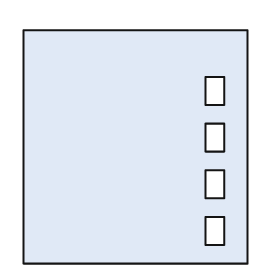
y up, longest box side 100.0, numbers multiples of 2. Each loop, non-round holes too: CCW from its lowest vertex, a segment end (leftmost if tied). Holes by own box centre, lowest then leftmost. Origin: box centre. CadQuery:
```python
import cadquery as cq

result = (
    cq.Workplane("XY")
    .moveTo(-48.0, -50.0)
    .lineTo(48.0, -50.0)
    .lineTo(48.0, 50.0)
    .lineTo(-48.0, 50.0)
    .close()
    .moveTo(30.0, -42.0)
    .lineTo(38.0, -42.0)
    .lineTo(38.0, -30.0)
    .lineTo(30.0, -30.0)
    .close()
    .moveTo(30.0, -22.0)
    .lineTo(38.0, -22.0)
    .lineTo(38.0, -10.0)
    .lineTo(30.0, -10.0)
    .close()
    .moveTo(30.0, -2.0)
    .lineTo(38.0, -2.0)
    .lineTo(38.0, 10.0)
    .lineTo(30.0, 10.0)
    .close()
    .moveTo(30.0, 18.0)
    .lineTo(38.0, 18.0)
    .lineTo(38.0, 30.0)
    .lineTo(30.0, 30.0)
    .close()
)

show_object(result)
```